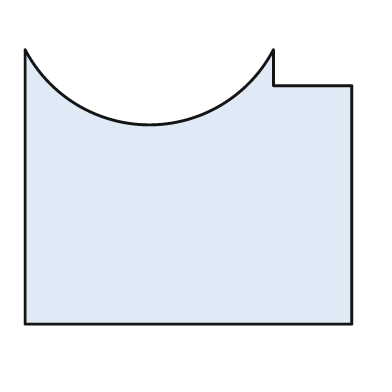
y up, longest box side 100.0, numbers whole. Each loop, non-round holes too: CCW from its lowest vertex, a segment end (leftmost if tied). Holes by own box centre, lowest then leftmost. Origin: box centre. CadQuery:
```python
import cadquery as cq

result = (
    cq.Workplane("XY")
    .moveTo(-50.0, -42.0)
    .lineTo(50.0, -42.0)
    .lineTo(50.0, 31.0)
    .lineTo(26.0, 31.0)
    .lineTo(26.0, 42.0)
    .threePointArc((-12.0, 19.0), (-50.0, 42.0))
    .close()
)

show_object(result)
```